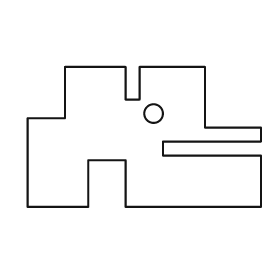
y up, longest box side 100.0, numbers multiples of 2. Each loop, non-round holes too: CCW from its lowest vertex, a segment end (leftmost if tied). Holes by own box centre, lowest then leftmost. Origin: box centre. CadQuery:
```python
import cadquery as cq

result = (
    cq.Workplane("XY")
    .moveTo(-50.0, -30.0)
    .lineTo(-24.0, -30.0)
    .lineTo(-24.0, -10.0)
    .lineTo(-8.0, -10.0)
    .lineTo(-8.0, -30.0)
    .lineTo(50.0, -30.0)
    .lineTo(50.0, -8.0)
    .lineTo(8.0, -8.0)
    .lineTo(8.0, -2.0)
    .lineTo(50.0, -2.0)
    .lineTo(50.0, 4.0)
    .lineTo(26.0, 4.0)
    .lineTo(26.0, 30.0)
    .lineTo(-2.0, 30.0)
    .lineTo(-2.0, 16.0)
    .lineTo(-8.0, 16.0)
    .lineTo(-8.0, 30.0)
    .lineTo(-34.0, 30.0)
    .lineTo(-34.0, 8.0)
    .lineTo(-50.0, 8.0)
    .close()
    .moveTo(4.0, 10.0)
    .circle(4.0)
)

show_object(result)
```